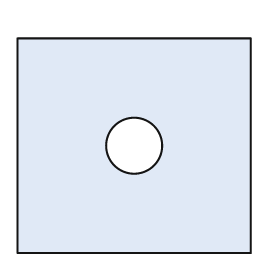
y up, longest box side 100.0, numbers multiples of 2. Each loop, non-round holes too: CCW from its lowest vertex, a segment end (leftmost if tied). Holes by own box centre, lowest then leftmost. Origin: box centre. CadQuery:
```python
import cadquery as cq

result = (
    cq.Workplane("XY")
    .moveTo(-50.0, -46.0)
    .lineTo(50.0, -46.0)
    .lineTo(50.0, 46.0)
    .lineTo(-50.0, 46.0)
    .close()
    .moveTo(0.0, 0.0)
    .circle(12.0)
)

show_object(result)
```